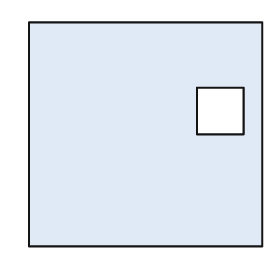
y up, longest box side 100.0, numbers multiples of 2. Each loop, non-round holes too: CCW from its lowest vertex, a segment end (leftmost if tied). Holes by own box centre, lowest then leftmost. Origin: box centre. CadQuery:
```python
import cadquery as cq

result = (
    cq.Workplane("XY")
    .moveTo(-50.0, -48.0)
    .lineTo(50.0, -48.0)
    .lineTo(50.0, 48.0)
    .lineTo(-50.0, 48.0)
    .close()
    .moveTo(22.0, 0.0)
    .lineTo(42.0, 0.0)
    .lineTo(42.0, 20.0)
    .lineTo(22.0, 20.0)
    .close()
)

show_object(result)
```